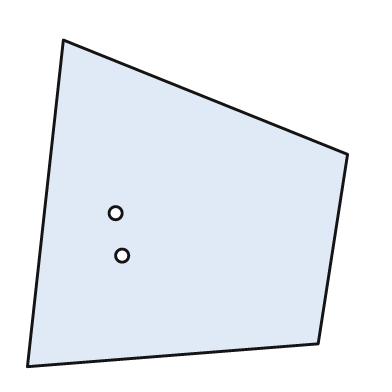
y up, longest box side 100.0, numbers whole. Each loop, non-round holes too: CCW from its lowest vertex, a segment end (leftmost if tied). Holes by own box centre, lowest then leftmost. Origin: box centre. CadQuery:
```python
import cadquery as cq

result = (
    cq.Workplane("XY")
    .moveTo(-49.0, -50.0)
    .lineTo(40.0, -43.0)
    .lineTo(49.0, 15.0)
    .lineTo(-38.0, 50.0)
    .close()
    .moveTo(-20.0, -16.0)
    .circle(2.0)
    .moveTo(-22.0, -3.0)
    .circle(2.0)
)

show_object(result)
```